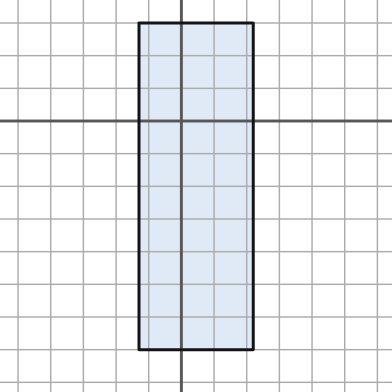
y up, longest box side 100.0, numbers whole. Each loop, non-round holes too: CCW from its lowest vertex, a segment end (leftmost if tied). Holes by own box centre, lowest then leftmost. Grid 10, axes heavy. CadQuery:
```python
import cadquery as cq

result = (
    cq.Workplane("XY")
    .moveTo(-13.0, -70.0)
    .lineTo(22.0, -70.0)
    .lineTo(22.0, 30.0)
    .lineTo(-13.0, 30.0)
    .close()
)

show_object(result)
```